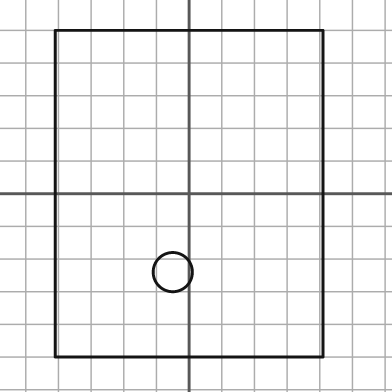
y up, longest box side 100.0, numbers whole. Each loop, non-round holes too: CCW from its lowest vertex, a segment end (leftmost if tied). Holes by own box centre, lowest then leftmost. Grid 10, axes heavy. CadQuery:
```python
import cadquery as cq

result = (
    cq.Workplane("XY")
    .moveTo(-41.0, -50.0)
    .lineTo(41.0, -50.0)
    .lineTo(41.0, 50.0)
    .lineTo(-41.0, 50.0)
    .close()
    .moveTo(-5.0, -24.0)
    .circle(6.0)
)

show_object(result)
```